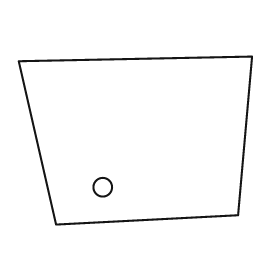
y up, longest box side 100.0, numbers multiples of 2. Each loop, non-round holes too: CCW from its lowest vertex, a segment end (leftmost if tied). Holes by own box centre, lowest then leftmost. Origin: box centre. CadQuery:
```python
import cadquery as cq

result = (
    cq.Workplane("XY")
    .moveTo(-34.0, -36.0)
    .lineTo(44.0, -32.0)
    .lineTo(50.0, 36.0)
    .lineTo(-50.0, 34.0)
    .close()
    .moveTo(-14.0, -20.0)
    .circle(4.0)
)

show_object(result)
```